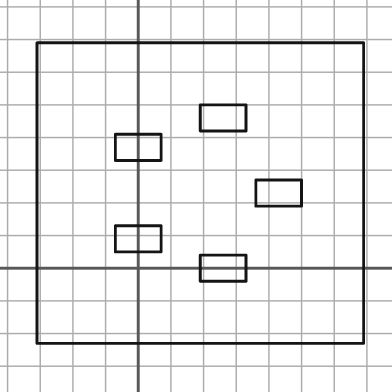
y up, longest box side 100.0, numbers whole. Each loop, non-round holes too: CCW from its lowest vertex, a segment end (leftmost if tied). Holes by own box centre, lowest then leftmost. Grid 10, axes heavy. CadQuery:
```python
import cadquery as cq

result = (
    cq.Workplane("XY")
    .moveTo(-31.0, -23.0)
    .lineTo(69.0, -23.0)
    .lineTo(69.0, 69.0)
    .lineTo(-31.0, 69.0)
    .close()
    .moveTo(19.0, -4.0)
    .lineTo(33.0, -4.0)
    .lineTo(33.0, 4.0)
    .lineTo(19.0, 4.0)
    .close()
    .moveTo(-7.0, 5.0)
    .lineTo(7.0, 5.0)
    .lineTo(7.0, 13.0)
    .lineTo(-7.0, 13.0)
    .close()
    .moveTo(36.0, 19.0)
    .lineTo(50.0, 19.0)
    .lineTo(50.0, 27.0)
    .lineTo(36.0, 27.0)
    .close()
    .moveTo(-7.0, 33.0)
    .lineTo(7.0, 33.0)
    .lineTo(7.0, 41.0)
    .lineTo(-7.0, 41.0)
    .close()
    .moveTo(19.0, 42.0)
    .lineTo(33.0, 42.0)
    .lineTo(33.0, 50.0)
    .lineTo(19.0, 50.0)
    .close()
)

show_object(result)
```